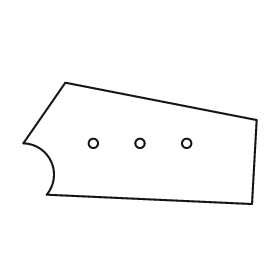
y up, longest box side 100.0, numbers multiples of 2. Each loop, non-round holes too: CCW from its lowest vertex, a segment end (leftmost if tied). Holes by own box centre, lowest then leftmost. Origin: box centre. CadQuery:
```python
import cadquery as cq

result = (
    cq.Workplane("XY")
    .moveTo(48.0, -26.0)
    .lineTo(50.0, 10.0)
    .lineTo(-32.0, 26.0)
    .lineTo(-50.0, 0.0)
    .threePointArc((-38.0, -8.0), (-40.0, -22.0))
    .close()
    .moveTo(-20.0, 0.0)
    .circle(2.0)
    .moveTo(0.0, 0.0)
    .circle(2.0)
    .moveTo(20.0, 0.0)
    .circle(2.0)
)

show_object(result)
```